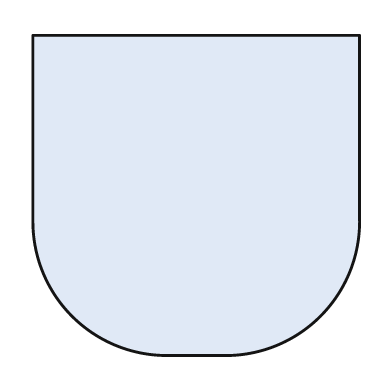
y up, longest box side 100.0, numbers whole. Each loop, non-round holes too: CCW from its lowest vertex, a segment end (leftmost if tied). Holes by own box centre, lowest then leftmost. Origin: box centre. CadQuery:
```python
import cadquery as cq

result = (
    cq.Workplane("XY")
    .moveTo(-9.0, -49.0)
    .lineTo(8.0, -49.0)
    .threePointArc((38.0, -37.0), (50.0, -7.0))
    .lineTo(50.0, 49.0)
    .lineTo(-50.0, 49.0)
    .lineTo(-50.0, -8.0)
    .threePointArc((-38.0, -37.0), (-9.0, -49.0))
    .close()
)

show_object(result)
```